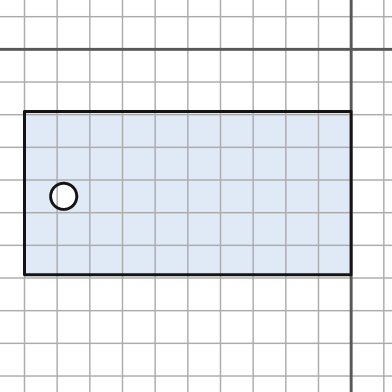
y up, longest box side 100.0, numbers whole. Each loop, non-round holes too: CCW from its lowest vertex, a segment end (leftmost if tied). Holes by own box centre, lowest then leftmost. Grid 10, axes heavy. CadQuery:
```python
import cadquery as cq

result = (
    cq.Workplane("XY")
    .moveTo(-100.0, -69.0)
    .lineTo(0.0, -69.0)
    .lineTo(0.0, -19.0)
    .lineTo(-100.0, -19.0)
    .close()
    .moveTo(-88.0, -45.0)
    .circle(4.0)
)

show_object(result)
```